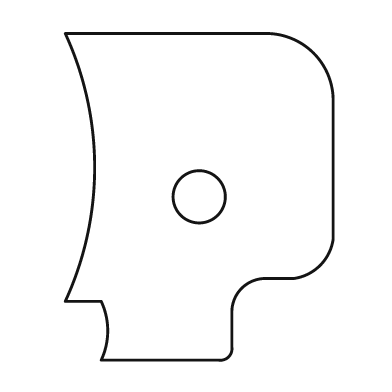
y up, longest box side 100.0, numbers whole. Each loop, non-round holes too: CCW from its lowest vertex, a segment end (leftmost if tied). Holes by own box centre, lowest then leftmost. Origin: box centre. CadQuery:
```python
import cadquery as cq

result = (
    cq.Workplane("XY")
    .moveTo(-30.0, -50.0)
    .lineTo(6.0, -50.0)
    .threePointArc((9.0, -49.0), (10.0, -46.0))
    .lineTo(10.0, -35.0)
    .threePointArc((13.0, -28.0), (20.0, -25.0))
    .lineTo(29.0, -25.0)
    .threePointArc((37.0, -21.0), (41.0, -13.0))
    .lineTo(41.0, 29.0)
    .threePointArc((35.0, 44.0), (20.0, 50.0))
    .lineTo(-41.0, 50.0)
    .threePointArc((-32.0, 9.0), (-41.0, -32.0))
    .lineTo(-30.0, -32.0)
    .threePointArc((-28.0, -41.0), (-30.0, -50.0))
    .close()
    .moveTo(0.0, 0.0)
    .circle(8.0)
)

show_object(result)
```